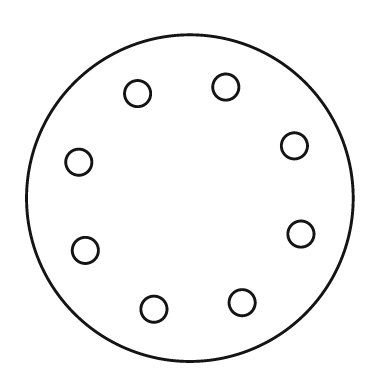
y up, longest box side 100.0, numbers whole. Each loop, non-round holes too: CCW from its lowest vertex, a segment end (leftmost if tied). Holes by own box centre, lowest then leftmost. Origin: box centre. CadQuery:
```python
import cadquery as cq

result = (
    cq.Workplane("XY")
    .moveTo(0.0, 0.0)
    .circle(50.0)
    .moveTo(-11.0, -34.0)
    .circle(4.0)
    .moveTo(16.0, -32.0)
    .circle(4.0)
    .moveTo(-32.0, -16.0)
    .circle(4.0)
    .moveTo(34.0, -11.0)
    .circle(4.0)
    .moveTo(-34.0, 11.0)
    .circle(4.0)
    .moveTo(32.0, 16.0)
    .circle(4.0)
    .moveTo(-16.0, 32.0)
    .circle(4.0)
    .moveTo(11.0, 34.0)
    .circle(4.0)
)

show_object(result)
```